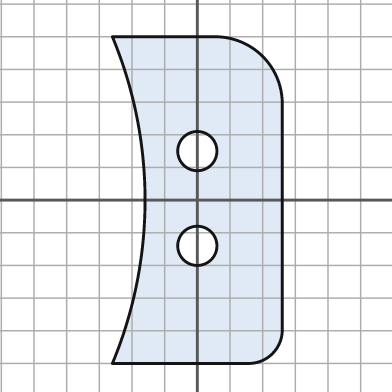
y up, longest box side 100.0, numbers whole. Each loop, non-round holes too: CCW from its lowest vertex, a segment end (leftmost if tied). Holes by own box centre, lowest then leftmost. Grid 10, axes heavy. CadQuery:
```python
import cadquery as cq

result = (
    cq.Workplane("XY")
    .moveTo(-26.0, -50.0)
    .lineTo(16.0, -50.0)
    .threePointArc((23.0, -47.0), (26.0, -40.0))
    .lineTo(26.0, 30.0)
    .threePointArc((20.0, 44.0), (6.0, 50.0))
    .lineTo(-26.0, 50.0)
    .threePointArc((-16.0, 0.0), (-26.0, -50.0))
    .close()
    .moveTo(0.0, -14.0)
    .circle(6.0)
    .moveTo(0.0, 15.0)
    .circle(6.0)
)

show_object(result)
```